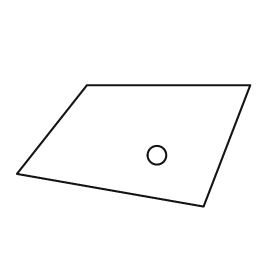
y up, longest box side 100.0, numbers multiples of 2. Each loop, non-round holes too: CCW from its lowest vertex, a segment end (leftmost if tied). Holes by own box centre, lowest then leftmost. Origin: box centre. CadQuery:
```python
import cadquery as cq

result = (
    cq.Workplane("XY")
    .moveTo(30.0, -26.0)
    .lineTo(50.0, 26.0)
    .lineTo(-20.0, 26.0)
    .lineTo(-50.0, -12.0)
    .close()
    .moveTo(10.0, -4.0)
    .circle(4.0)
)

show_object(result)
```